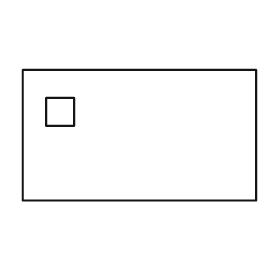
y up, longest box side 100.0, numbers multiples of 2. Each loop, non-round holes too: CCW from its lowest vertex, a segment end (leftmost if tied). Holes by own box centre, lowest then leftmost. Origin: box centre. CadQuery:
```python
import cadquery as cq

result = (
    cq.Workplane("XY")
    .moveTo(-50.0, -28.0)
    .lineTo(50.0, -28.0)
    .lineTo(50.0, 28.0)
    .lineTo(-50.0, 28.0)
    .close()
    .moveTo(-40.0, 4.0)
    .lineTo(-28.0, 4.0)
    .lineTo(-28.0, 16.0)
    .lineTo(-40.0, 16.0)
    .close()
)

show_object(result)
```